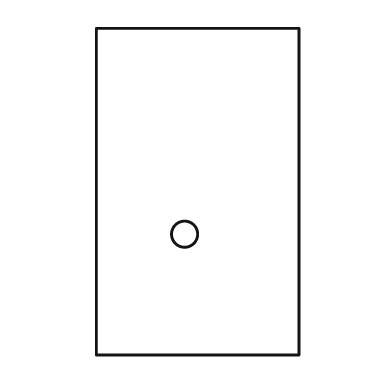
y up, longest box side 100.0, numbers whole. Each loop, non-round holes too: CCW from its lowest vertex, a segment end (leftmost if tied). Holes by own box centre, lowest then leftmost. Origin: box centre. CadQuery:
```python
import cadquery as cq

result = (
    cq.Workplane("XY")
    .moveTo(-31.0, -50.0)
    .lineTo(31.0, -50.0)
    .lineTo(31.0, 50.0)
    .lineTo(-31.0, 50.0)
    .close()
    .moveTo(-4.0, -13.0)
    .circle(4.0)
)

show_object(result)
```